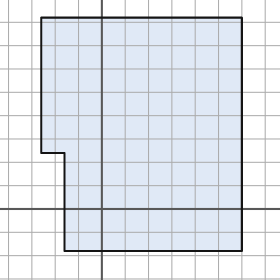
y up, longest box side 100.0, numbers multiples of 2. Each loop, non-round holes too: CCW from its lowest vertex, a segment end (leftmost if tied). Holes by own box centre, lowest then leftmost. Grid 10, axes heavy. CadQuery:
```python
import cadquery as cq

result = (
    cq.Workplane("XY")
    .moveTo(-16.0, -18.0)
    .lineTo(60.0, -18.0)
    .lineTo(60.0, 82.0)
    .lineTo(-26.0, 82.0)
    .lineTo(-26.0, 24.0)
    .lineTo(-16.0, 24.0)
    .close()
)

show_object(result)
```